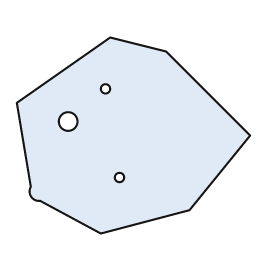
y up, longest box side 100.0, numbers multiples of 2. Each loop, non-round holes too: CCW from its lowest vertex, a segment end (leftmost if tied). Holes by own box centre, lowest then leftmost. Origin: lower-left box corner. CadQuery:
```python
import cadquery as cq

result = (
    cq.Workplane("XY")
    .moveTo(36.0, 0.0)
    .lineTo(74.0, 10.0)
    .lineTo(100.0, 42.0)
    .lineTo(64.0, 78.0)
    .lineTo(40.0, 84.0)
    .lineTo(0.0, 56.0)
    .lineTo(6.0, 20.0)
    .threePointArc((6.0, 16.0), (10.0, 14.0))
    .close()
    .moveTo(44.0, 24.0)
    .circle(2.0)
    .moveTo(22.0, 48.0)
    .circle(4.0)
    .moveTo(38.0, 62.0)
    .circle(2.0)
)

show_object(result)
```